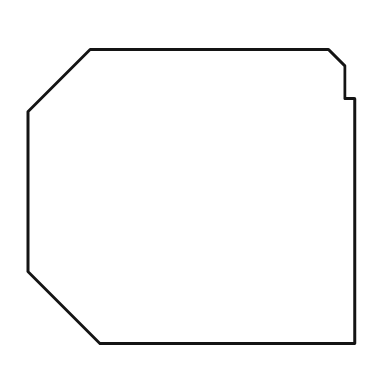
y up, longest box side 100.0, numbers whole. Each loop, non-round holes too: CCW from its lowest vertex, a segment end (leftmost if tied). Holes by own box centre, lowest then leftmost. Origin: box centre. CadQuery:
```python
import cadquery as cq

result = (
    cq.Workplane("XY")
    .moveTo(-28.0, -45.0)
    .lineTo(50.0, -45.0)
    .lineTo(50.0, 30.0)
    .lineTo(47.0, 30.0)
    .lineTo(47.0, 40.0)
    .lineTo(42.0, 45.0)
    .lineTo(-31.0, 45.0)
    .lineTo(-50.0, 26.0)
    .lineTo(-50.0, -23.0)
    .close()
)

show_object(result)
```